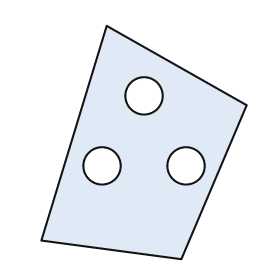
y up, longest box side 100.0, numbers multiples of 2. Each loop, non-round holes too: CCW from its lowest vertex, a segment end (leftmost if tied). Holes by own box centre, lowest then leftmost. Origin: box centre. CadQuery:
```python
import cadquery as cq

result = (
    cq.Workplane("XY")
    .moveTo(16.0, -50.0)
    .lineTo(44.0, 16.0)
    .lineTo(-16.0, 50.0)
    .lineTo(-44.0, -42.0)
    .close()
    .moveTo(-18.0, -10.0)
    .circle(8.0)
    .moveTo(18.0, -10.0)
    .circle(8.0)
    .moveTo(0.0, 20.0)
    .circle(8.0)
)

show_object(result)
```